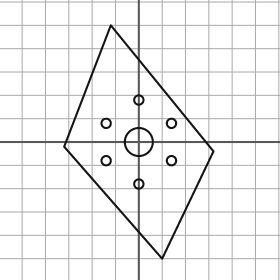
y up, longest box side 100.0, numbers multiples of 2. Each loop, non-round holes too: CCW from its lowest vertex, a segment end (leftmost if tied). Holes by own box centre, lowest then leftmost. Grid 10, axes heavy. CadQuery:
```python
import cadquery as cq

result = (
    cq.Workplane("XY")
    .moveTo(10.0, -50.0)
    .lineTo(32.0, -4.0)
    .lineTo(-12.0, 50.0)
    .lineTo(-32.0, -2.0)
    .close()
    .moveTo(0.0, -18.0)
    .circle(2.0)
    .moveTo(-14.0, -8.0)
    .circle(2.0)
    .moveTo(14.0, -8.0)
    .circle(2.0)
    .moveTo(0.0, 0.0)
    .circle(6.0)
    .moveTo(-14.0, 8.0)
    .circle(2.0)
    .moveTo(14.0, 8.0)
    .circle(2.0)
    .moveTo(0.0, 18.0)
    .circle(2.0)
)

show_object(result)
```